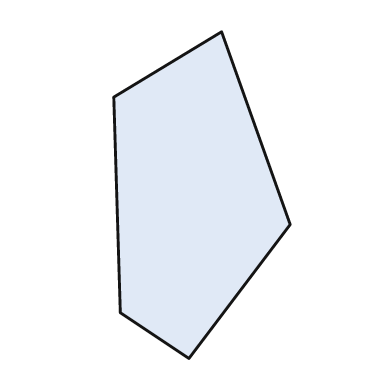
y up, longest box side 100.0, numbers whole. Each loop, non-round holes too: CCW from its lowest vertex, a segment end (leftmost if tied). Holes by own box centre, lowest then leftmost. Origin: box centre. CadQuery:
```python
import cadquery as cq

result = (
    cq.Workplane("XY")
    .moveTo(-4.0, -50.0)
    .lineTo(27.0, -9.0)
    .lineTo(6.0, 50.0)
    .lineTo(-27.0, 30.0)
    .lineTo(-25.0, -36.0)
    .close()
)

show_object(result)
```